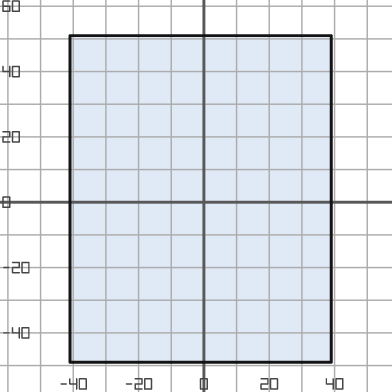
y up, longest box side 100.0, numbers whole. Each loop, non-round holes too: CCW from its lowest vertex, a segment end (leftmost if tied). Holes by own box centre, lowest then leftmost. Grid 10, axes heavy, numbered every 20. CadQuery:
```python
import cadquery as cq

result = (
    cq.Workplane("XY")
    .moveTo(-41.0, -49.0)
    .lineTo(39.0, -49.0)
    .lineTo(39.0, 51.0)
    .lineTo(-41.0, 51.0)
    .close()
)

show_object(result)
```